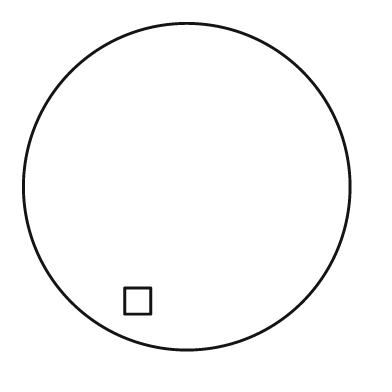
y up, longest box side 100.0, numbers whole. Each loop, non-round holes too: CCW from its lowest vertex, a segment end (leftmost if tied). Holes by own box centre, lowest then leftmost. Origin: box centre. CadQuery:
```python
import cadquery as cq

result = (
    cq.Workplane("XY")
    .moveTo(0.0, 0.0)
    .circle(50.0)
    .moveTo(-19.0, -39.0)
    .lineTo(-11.0, -39.0)
    .lineTo(-11.0, -31.0)
    .lineTo(-19.0, -31.0)
    .close()
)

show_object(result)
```